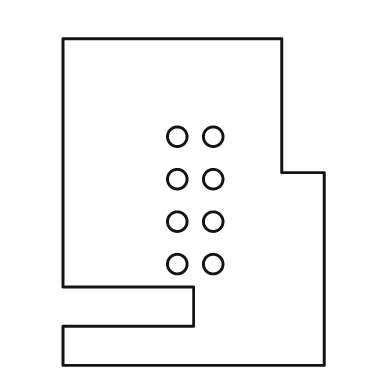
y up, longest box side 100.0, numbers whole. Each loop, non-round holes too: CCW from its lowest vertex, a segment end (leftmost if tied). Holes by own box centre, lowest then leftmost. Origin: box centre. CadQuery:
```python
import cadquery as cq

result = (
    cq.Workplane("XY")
    .moveTo(-40.0, -50.0)
    .lineTo(40.0, -50.0)
    .lineTo(40.0, 9.0)
    .lineTo(27.0, 9.0)
    .lineTo(27.0, 50.0)
    .lineTo(-40.0, 50.0)
    .lineTo(-40.0, -26.0)
    .lineTo(0.0, -26.0)
    .lineTo(0.0, -38.0)
    .lineTo(-40.0, -38.0)
    .close()
    .moveTo(-5.0, -19.0)
    .circle(3.0)
    .moveTo(6.0, -19.0)
    .circle(3.0)
    .moveTo(-5.0, -6.0)
    .circle(3.0)
    .moveTo(6.0, -6.0)
    .circle(3.0)
    .moveTo(-5.0, 7.0)
    .circle(3.0)
    .moveTo(6.0, 7.0)
    .circle(3.0)
    .moveTo(-5.0, 20.0)
    .circle(3.0)
    .moveTo(6.0, 20.0)
    .circle(3.0)
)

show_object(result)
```